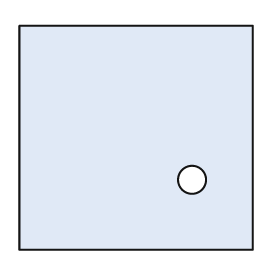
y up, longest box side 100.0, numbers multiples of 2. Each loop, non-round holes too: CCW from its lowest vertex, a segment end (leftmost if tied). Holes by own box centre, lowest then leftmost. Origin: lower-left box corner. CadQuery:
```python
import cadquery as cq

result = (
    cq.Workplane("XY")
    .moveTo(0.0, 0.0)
    .lineTo(100.0, 0.0)
    .lineTo(100.0, 96.0)
    .lineTo(0.0, 96.0)
    .close()
    .moveTo(74.0, 30.0)
    .circle(6.0)
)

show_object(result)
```